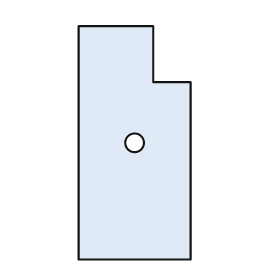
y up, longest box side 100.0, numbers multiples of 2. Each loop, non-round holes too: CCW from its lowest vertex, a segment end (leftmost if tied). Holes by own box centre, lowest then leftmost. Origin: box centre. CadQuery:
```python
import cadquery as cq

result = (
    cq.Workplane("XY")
    .moveTo(-24.0, -50.0)
    .lineTo(24.0, -50.0)
    .lineTo(24.0, 26.0)
    .lineTo(8.0, 26.0)
    .lineTo(8.0, 50.0)
    .lineTo(-24.0, 50.0)
    .close()
    .moveTo(0.0, 0.0)
    .circle(4.0)
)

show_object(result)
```